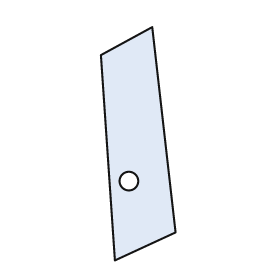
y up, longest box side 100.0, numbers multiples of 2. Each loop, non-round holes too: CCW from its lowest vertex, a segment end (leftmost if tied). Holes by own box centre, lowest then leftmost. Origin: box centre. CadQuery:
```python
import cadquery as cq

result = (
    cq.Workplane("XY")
    .moveTo(-10.0, -50.0)
    .lineTo(16.0, -38.0)
    .lineTo(6.0, 50.0)
    .lineTo(-16.0, 38.0)
    .close()
    .moveTo(-4.0, -16.0)
    .circle(4.0)
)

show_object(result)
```